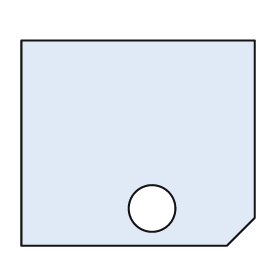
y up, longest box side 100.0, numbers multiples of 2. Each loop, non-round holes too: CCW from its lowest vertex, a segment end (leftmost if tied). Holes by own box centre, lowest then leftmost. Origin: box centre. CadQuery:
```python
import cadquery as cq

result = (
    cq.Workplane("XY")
    .moveTo(-50.0, -44.0)
    .lineTo(38.0, -44.0)
    .lineTo(50.0, -32.0)
    .lineTo(50.0, 44.0)
    .lineTo(-50.0, 44.0)
    .close()
    .moveTo(6.0, -28.0)
    .circle(10.0)
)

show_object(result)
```